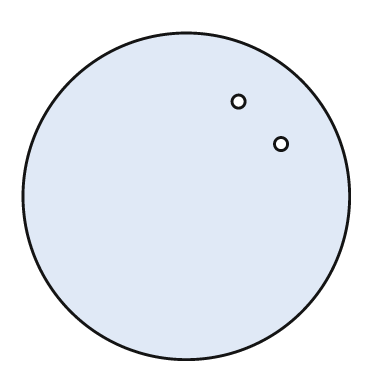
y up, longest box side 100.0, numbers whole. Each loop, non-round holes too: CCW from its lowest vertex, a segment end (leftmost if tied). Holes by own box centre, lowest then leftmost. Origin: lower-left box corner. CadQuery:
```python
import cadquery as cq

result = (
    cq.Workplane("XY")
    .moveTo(50.0, 50.0)
    .circle(50.0)
    .moveTo(79.0, 66.0)
    .circle(2.0)
    .moveTo(66.0, 79.0)
    .circle(2.0)
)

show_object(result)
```